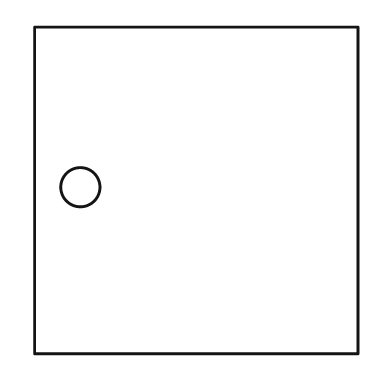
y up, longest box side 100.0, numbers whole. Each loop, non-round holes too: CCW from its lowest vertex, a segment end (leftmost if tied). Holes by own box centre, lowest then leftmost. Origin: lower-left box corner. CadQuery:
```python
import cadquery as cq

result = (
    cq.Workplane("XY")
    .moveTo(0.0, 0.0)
    .lineTo(99.0, 0.0)
    .lineTo(99.0, 100.0)
    .lineTo(0.0, 100.0)
    .close()
    .moveTo(14.0, 51.0)
    .circle(6.0)
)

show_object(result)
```